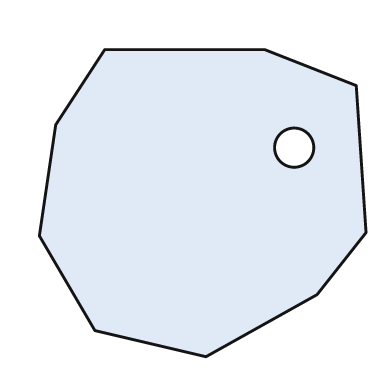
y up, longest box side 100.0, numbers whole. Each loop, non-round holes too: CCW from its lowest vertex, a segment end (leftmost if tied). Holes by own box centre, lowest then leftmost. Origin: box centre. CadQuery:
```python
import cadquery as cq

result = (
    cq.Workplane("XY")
    .moveTo(1.0, -47.0)
    .lineTo(35.0, -28.0)
    .lineTo(50.0, -9.0)
    .lineTo(47.0, 36.0)
    .lineTo(19.0, 47.0)
    .lineTo(-30.0, 47.0)
    .lineTo(-45.0, 24.0)
    .lineTo(-50.0, -10.0)
    .lineTo(-33.0, -39.0)
    .close()
    .moveTo(28.0, 17.0)
    .circle(6.0)
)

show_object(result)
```